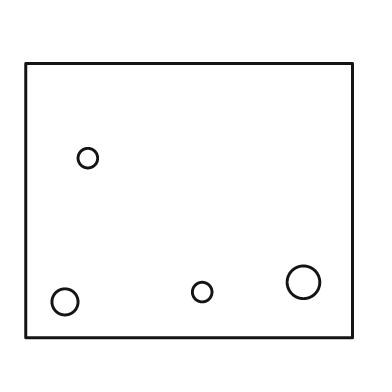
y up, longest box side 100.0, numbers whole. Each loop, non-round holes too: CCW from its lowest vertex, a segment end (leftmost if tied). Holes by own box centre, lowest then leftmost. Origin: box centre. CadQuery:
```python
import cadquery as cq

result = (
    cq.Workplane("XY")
    .moveTo(-50.0, -42.0)
    .lineTo(50.0, -42.0)
    .lineTo(50.0, 42.0)
    .lineTo(-50.0, 42.0)
    .close()
    .moveTo(-38.0, -31.0)
    .circle(4.0)
    .moveTo(4.0, -28.0)
    .circle(3.0)
    .moveTo(35.0, -25.0)
    .circle(5.0)
    .moveTo(-31.0, 13.0)
    .circle(3.0)
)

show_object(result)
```